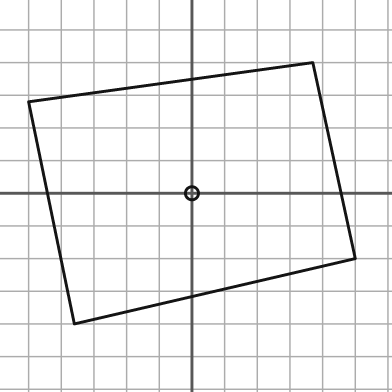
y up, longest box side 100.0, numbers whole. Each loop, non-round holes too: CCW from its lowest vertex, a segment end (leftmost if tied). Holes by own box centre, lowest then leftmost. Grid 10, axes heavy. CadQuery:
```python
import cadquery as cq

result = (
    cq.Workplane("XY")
    .moveTo(-36.0, -40.0)
    .lineTo(50.0, -20.0)
    .lineTo(37.0, 40.0)
    .lineTo(-50.0, 28.0)
    .close()
    .moveTo(0.0, 0.0)
    .circle(2.0)
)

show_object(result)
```